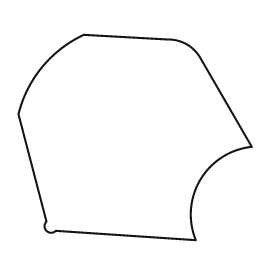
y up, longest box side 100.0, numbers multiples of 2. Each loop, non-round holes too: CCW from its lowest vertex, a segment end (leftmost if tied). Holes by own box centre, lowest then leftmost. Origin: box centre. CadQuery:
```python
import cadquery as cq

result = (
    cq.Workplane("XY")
    .moveTo(26.0, -44.0)
    .threePointArc((28.0, -18.0), (50.0, -4.0))
    .lineTo(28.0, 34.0)
    .threePointArc((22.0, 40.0), (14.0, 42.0))
    .lineTo(-22.0, 44.0)
    .threePointArc((-40.0, 30.0), (-50.0, 10.0))
    .lineTo(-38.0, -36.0)
    .threePointArc((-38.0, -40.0), (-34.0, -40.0))
    .close()
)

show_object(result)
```